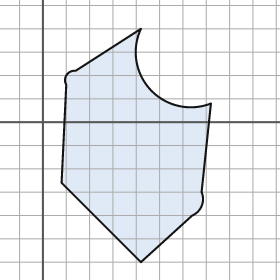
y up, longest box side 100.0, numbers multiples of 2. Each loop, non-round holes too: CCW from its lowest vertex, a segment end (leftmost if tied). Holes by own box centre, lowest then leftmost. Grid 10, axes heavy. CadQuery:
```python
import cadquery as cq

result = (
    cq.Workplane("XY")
    .moveTo(42.0, -60.0)
    .lineTo(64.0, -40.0)
    .threePointArc((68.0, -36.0), (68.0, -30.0))
    .lineTo(72.0, 8.0)
    .threePointArc((46.0, 14.0), (42.0, 40.0))
    .lineTo(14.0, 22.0)
    .threePointArc((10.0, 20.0), (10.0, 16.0))
    .lineTo(8.0, -26.0)
    .close()
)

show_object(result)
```